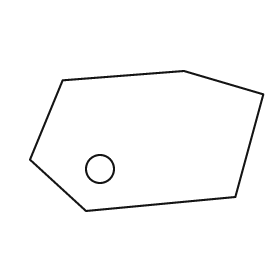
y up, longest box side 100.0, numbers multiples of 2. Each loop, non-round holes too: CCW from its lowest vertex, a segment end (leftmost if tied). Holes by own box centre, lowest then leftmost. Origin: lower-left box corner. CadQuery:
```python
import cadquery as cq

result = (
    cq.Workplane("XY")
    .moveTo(24.0, 0.0)
    .lineTo(88.0, 6.0)
    .lineTo(100.0, 50.0)
    .lineTo(66.0, 60.0)
    .lineTo(14.0, 56.0)
    .lineTo(0.0, 22.0)
    .close()
    .moveTo(30.0, 18.0)
    .circle(6.0)
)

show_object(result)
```